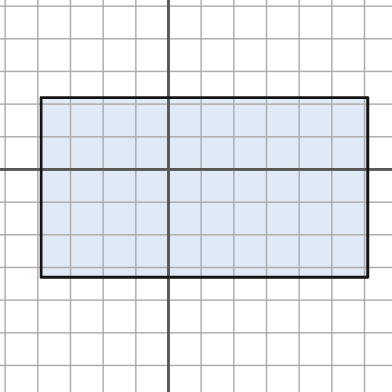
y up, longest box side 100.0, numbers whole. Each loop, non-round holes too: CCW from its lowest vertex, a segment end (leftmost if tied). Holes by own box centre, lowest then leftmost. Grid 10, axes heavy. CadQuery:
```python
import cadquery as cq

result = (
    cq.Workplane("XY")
    .moveTo(-39.0, -33.0)
    .lineTo(61.0, -33.0)
    .lineTo(61.0, 22.0)
    .lineTo(-39.0, 22.0)
    .close()
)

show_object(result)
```